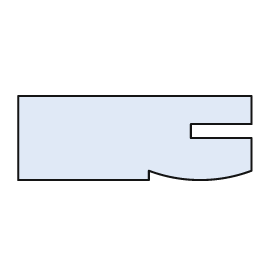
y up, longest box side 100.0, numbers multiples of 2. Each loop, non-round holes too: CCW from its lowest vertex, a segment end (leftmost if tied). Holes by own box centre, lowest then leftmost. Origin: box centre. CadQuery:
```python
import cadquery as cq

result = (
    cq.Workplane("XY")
    .moveTo(-50.0, -18.0)
    .lineTo(6.0, -18.0)
    .lineTo(6.0, -14.0)
    .threePointArc((28.0, -18.0), (50.0, -14.0))
    .lineTo(50.0, 0.0)
    .lineTo(24.0, 0.0)
    .lineTo(24.0, 6.0)
    .lineTo(50.0, 6.0)
    .lineTo(50.0, 18.0)
    .lineTo(-50.0, 18.0)
    .close()
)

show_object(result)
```